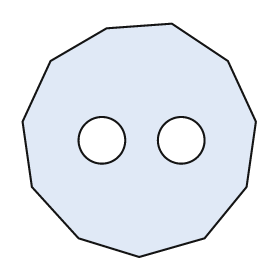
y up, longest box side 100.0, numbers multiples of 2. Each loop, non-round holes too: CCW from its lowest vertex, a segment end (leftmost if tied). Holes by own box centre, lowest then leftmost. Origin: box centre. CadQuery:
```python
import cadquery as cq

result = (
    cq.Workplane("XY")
    .moveTo(0.0, -50.0)
    .lineTo(28.0, -42.0)
    .lineTo(46.0, -20.0)
    .lineTo(50.0, 8.0)
    .lineTo(38.0, 34.0)
    .lineTo(14.0, 50.0)
    .lineTo(-14.0, 48.0)
    .lineTo(-38.0, 34.0)
    .lineTo(-50.0, 8.0)
    .lineTo(-46.0, -20.0)
    .lineTo(-26.0, -42.0)
    .close()
    .moveTo(-16.0, 0.0)
    .circle(10.0)
    .moveTo(18.0, 0.0)
    .circle(10.0)
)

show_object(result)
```